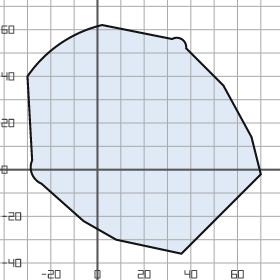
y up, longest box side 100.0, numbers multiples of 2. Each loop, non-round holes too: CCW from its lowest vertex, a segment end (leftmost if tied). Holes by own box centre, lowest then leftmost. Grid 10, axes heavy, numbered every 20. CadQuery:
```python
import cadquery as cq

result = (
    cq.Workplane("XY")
    .moveTo(36.0, -36.0)
    .lineTo(70.0, -2.0)
    .lineTo(66.0, 14.0)
    .lineTo(54.0, 36.0)
    .lineTo(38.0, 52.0)
    .threePointArc((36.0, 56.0), (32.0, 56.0))
    .lineTo(2.0, 62.0)
    .threePointArc((-16.0, 54.0), (-30.0, 40.0))
    .lineTo(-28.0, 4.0)
    .threePointArc((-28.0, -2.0), (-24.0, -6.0))
    .lineTo(-6.0, -22.0)
    .lineTo(8.0, -30.0)
    .close()
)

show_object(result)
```